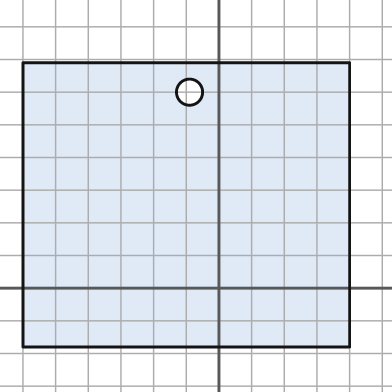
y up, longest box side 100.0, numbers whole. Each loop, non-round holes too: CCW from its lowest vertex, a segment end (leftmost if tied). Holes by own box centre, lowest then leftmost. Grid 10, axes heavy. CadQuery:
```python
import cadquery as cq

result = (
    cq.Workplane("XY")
    .moveTo(-60.0, -18.0)
    .lineTo(40.0, -18.0)
    .lineTo(40.0, 69.0)
    .lineTo(-60.0, 69.0)
    .close()
    .moveTo(-9.0, 60.0)
    .circle(4.0)
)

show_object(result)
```